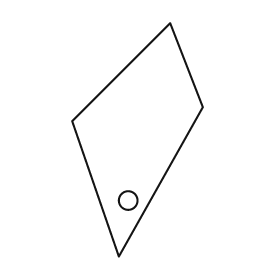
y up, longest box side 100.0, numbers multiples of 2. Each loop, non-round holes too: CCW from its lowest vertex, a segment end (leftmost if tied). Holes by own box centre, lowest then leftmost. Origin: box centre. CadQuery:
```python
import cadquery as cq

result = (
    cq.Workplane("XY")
    .moveTo(-8.0, -50.0)
    .lineTo(28.0, 14.0)
    .lineTo(14.0, 50.0)
    .lineTo(-28.0, 8.0)
    .close()
    .moveTo(-4.0, -26.0)
    .circle(4.0)
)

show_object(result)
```